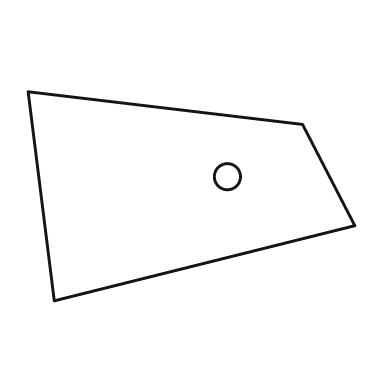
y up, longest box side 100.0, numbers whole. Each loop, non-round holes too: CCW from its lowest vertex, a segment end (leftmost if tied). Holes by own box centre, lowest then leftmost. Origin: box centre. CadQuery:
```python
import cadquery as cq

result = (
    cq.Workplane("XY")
    .moveTo(-42.0, -32.0)
    .lineTo(50.0, -9.0)
    .lineTo(34.0, 22.0)
    .lineTo(-50.0, 32.0)
    .close()
    .moveTo(11.0, 6.0)
    .circle(4.0)
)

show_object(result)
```